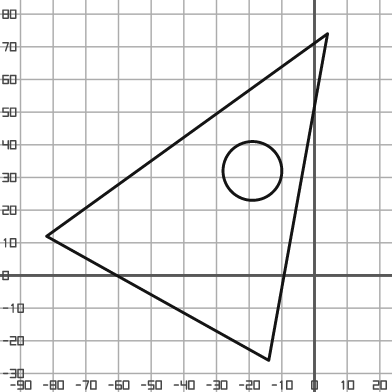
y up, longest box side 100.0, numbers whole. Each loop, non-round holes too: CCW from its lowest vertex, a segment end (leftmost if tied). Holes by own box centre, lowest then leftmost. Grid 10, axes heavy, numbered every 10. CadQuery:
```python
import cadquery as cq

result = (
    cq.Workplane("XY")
    .moveTo(-14.0, -26.0)
    .lineTo(4.0, 74.0)
    .lineTo(-82.0, 12.0)
    .close()
    .moveTo(-19.0, 32.0)
    .circle(9.0)
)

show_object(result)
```